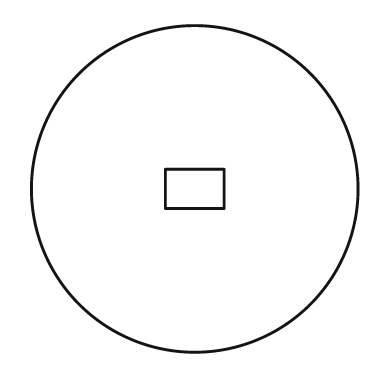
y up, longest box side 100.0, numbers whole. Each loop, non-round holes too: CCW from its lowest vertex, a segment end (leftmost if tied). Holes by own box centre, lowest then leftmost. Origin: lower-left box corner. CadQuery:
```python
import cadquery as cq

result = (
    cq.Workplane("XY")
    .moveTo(50.0, 50.0)
    .circle(50.0)
    .moveTo(41.0, 44.0)
    .lineTo(59.0, 44.0)
    .lineTo(59.0, 56.0)
    .lineTo(41.0, 56.0)
    .close()
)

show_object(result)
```